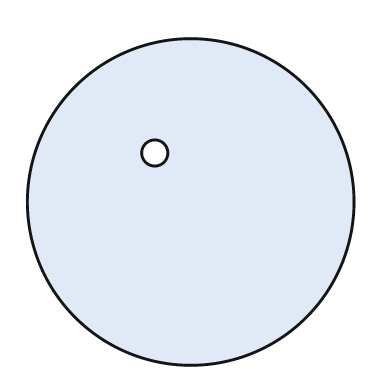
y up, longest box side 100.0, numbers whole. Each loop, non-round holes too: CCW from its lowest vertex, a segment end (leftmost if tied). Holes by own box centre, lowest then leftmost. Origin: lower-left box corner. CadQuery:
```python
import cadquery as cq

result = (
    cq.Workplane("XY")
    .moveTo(50.0, 50.0)
    .circle(50.0)
    .moveTo(39.0, 65.0)
    .circle(4.0)
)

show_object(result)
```